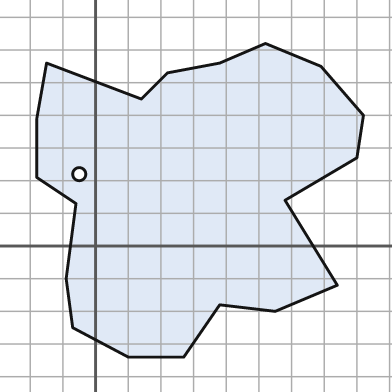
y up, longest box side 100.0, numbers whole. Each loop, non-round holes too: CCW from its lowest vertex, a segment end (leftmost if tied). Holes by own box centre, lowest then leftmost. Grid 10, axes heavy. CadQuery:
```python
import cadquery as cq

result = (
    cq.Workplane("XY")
    .moveTo(10.0, -34.0)
    .lineTo(27.0, -34.0)
    .lineTo(38.0, -18.0)
    .lineTo(55.0, -20.0)
    .lineTo(74.0, -12.0)
    .lineTo(58.0, 14.0)
    .lineTo(80.0, 27.0)
    .lineTo(82.0, 40.0)
    .lineTo(69.0, 55.0)
    .lineTo(52.0, 62.0)
    .lineTo(38.0, 56.0)
    .lineTo(22.0, 53.0)
    .lineTo(14.0, 45.0)
    .lineTo(-15.0, 56.0)
    .lineTo(-18.0, 39.0)
    .lineTo(-18.0, 21.0)
    .lineTo(-6.0, 13.0)
    .lineTo(-9.0, -10.0)
    .lineTo(-7.0, -25.0)
    .close()
    .moveTo(-5.0, 22.0)
    .circle(2.0)
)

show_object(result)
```